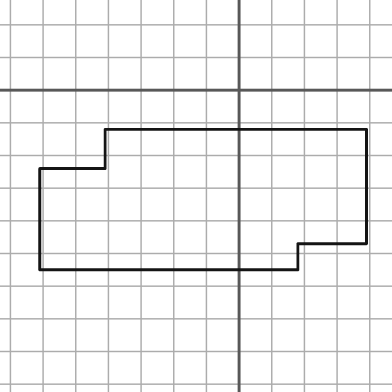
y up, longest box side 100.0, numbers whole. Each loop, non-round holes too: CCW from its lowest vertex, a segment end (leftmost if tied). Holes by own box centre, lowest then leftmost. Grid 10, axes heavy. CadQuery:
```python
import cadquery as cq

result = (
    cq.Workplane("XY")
    .moveTo(-61.0, -55.0)
    .lineTo(18.0, -55.0)
    .lineTo(18.0, -47.0)
    .lineTo(39.0, -47.0)
    .lineTo(39.0, -12.0)
    .lineTo(-41.0, -12.0)
    .lineTo(-41.0, -24.0)
    .lineTo(-61.0, -24.0)
    .close()
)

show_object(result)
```